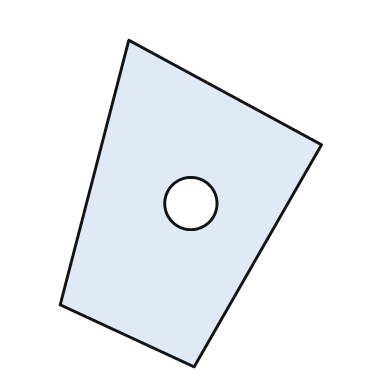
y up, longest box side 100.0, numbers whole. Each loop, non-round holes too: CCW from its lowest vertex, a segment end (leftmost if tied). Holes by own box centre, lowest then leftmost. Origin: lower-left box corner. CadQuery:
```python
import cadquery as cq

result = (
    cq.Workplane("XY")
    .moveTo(41.0, 0.0)
    .lineTo(80.0, 68.0)
    .lineTo(21.0, 100.0)
    .lineTo(0.0, 19.0)
    .close()
    .moveTo(40.0, 50.0)
    .circle(8.0)
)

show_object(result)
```